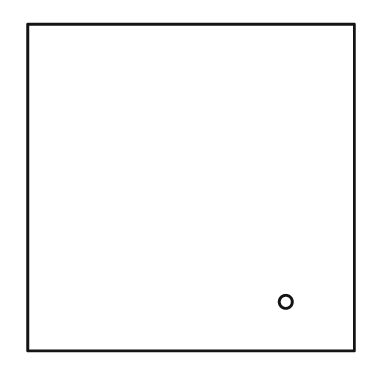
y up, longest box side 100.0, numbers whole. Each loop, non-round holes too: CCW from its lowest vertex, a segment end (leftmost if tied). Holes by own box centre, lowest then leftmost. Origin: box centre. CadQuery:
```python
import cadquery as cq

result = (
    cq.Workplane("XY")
    .moveTo(-50.0, -50.0)
    .lineTo(50.0, -50.0)
    .lineTo(50.0, 50.0)
    .lineTo(-50.0, 50.0)
    .close()
    .moveTo(29.0, -35.0)
    .circle(2.0)
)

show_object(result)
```